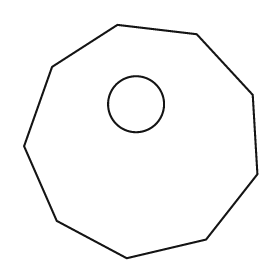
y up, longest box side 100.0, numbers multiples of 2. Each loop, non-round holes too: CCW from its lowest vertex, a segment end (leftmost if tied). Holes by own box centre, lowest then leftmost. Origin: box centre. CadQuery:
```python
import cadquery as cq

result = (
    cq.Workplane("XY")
    .moveTo(-6.0, -50.0)
    .lineTo(28.0, -42.0)
    .lineTo(50.0, -14.0)
    .lineTo(48.0, 20.0)
    .lineTo(24.0, 46.0)
    .lineTo(-10.0, 50.0)
    .lineTo(-38.0, 32.0)
    .lineTo(-50.0, -2.0)
    .lineTo(-36.0, -34.0)
    .close()
    .moveTo(-2.0, 16.0)
    .circle(12.0)
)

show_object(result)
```